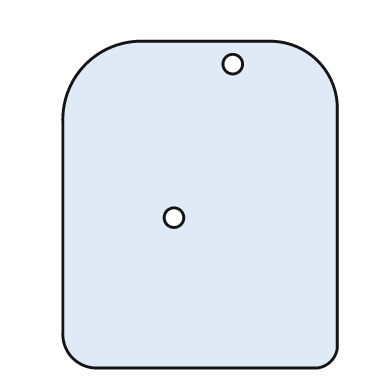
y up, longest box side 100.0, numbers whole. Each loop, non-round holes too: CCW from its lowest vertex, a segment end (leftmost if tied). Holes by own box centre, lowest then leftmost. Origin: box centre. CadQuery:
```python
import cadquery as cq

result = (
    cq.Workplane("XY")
    .moveTo(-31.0, -50.0)
    .lineTo(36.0, -50.0)
    .threePointArc((40.0, -48.0), (42.0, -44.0))
    .lineTo(42.0, 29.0)
    .threePointArc((36.0, 44.0), (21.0, 50.0))
    .lineTo(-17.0, 50.0)
    .threePointArc((-35.0, 43.0), (-42.0, 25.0))
    .lineTo(-42.0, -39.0)
    .threePointArc((-39.0, -47.0), (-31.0, -50.0))
    .close()
    .moveTo(-8.0, -4.0)
    .circle(3.0)
    .moveTo(10.0, 43.0)
    .circle(3.0)
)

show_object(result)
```